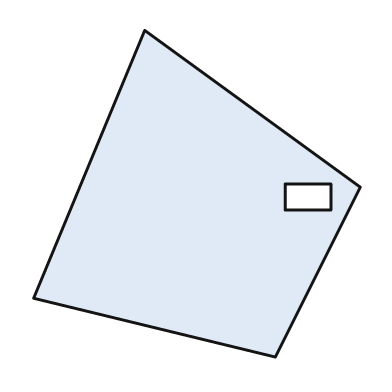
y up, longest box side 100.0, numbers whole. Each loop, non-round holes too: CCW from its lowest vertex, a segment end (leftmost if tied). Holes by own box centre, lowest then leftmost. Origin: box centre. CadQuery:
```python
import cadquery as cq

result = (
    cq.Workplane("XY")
    .moveTo(24.0, -50.0)
    .lineTo(50.0, 2.0)
    .lineTo(-16.0, 50.0)
    .lineTo(-50.0, -32.0)
    .close()
    .moveTo(27.0, -5.0)
    .lineTo(41.0, -5.0)
    .lineTo(41.0, 3.0)
    .lineTo(27.0, 3.0)
    .close()
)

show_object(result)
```